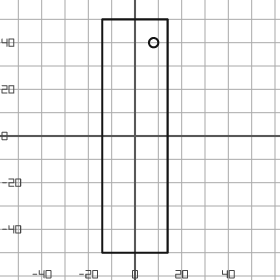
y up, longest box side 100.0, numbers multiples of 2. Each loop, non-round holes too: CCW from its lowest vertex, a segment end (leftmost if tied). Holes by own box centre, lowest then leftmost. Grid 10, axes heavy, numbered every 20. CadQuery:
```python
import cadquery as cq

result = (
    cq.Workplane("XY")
    .moveTo(-14.0, -50.0)
    .lineTo(14.0, -50.0)
    .lineTo(14.0, 50.0)
    .lineTo(-14.0, 50.0)
    .close()
    .moveTo(8.0, 40.0)
    .circle(2.0)
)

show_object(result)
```